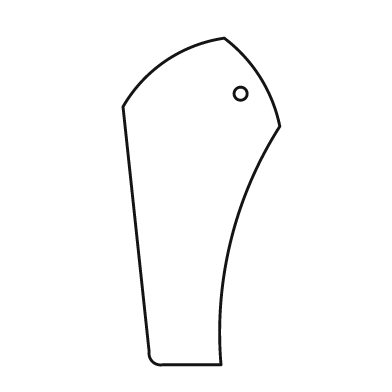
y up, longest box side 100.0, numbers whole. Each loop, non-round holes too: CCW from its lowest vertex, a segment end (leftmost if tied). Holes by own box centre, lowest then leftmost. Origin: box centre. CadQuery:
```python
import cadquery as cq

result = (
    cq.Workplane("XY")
    .moveTo(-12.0, -50.0)
    .lineTo(6.0, -50.0)
    .threePointArc((9.0, -12.0), (24.0, 23.0))
    .threePointArc((18.0, 38.0), (7.0, 50.0))
    .threePointArc((-11.0, 43.0), (-24.0, 29.0))
    .lineTo(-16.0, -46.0)
    .threePointArc((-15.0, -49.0), (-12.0, -50.0))
    .close()
    .moveTo(12.0, 33.0)
    .circle(2.0)
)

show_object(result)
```